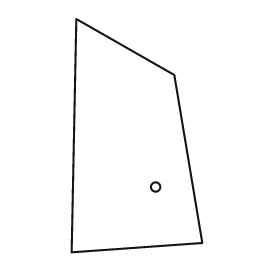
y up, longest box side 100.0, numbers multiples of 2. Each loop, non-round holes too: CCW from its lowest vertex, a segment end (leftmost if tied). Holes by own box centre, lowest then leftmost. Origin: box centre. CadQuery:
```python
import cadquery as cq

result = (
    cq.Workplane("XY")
    .moveTo(-28.0, -50.0)
    .lineTo(28.0, -46.0)
    .lineTo(16.0, 26.0)
    .lineTo(-26.0, 50.0)
    .close()
    .moveTo(8.0, -22.0)
    .circle(2.0)
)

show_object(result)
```